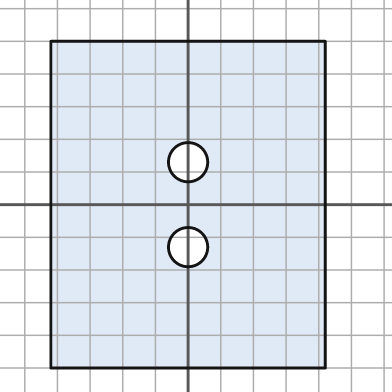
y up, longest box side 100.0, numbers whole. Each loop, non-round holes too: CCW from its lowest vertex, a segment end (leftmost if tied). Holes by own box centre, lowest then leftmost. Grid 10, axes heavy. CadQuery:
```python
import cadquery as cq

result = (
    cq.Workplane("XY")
    .moveTo(-42.0, -50.0)
    .lineTo(42.0, -50.0)
    .lineTo(42.0, 50.0)
    .lineTo(-42.0, 50.0)
    .close()
    .moveTo(0.0, -13.0)
    .circle(6.0)
    .moveTo(0.0, 13.0)
    .circle(6.0)
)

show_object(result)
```